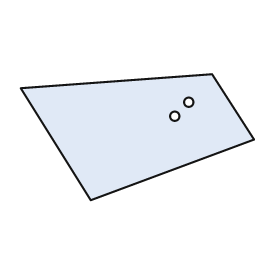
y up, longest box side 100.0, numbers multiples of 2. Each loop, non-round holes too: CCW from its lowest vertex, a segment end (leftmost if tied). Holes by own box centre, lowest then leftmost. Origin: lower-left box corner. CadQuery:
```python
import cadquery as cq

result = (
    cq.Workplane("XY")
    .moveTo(30.0, 0.0)
    .lineTo(100.0, 26.0)
    .lineTo(82.0, 54.0)
    .lineTo(0.0, 48.0)
    .close()
    .moveTo(66.0, 36.0)
    .circle(2.0)
    .moveTo(72.0, 42.0)
    .circle(2.0)
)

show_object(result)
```